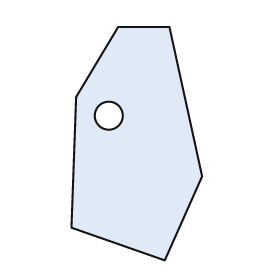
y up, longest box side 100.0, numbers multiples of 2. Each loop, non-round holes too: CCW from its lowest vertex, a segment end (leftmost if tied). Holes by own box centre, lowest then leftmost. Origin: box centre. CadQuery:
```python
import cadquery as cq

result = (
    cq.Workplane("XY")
    .moveTo(12.0, -50.0)
    .lineTo(28.0, -14.0)
    .lineTo(14.0, 50.0)
    .lineTo(-8.0, 50.0)
    .lineTo(-26.0, 20.0)
    .lineTo(-28.0, -36.0)
    .close()
    .moveTo(-12.0, 12.0)
    .circle(6.0)
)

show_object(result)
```